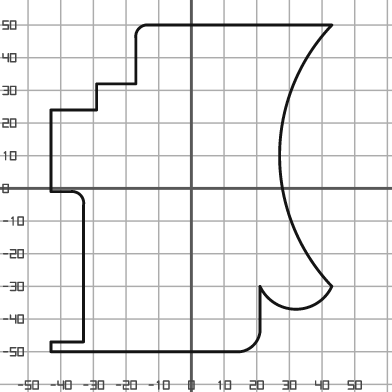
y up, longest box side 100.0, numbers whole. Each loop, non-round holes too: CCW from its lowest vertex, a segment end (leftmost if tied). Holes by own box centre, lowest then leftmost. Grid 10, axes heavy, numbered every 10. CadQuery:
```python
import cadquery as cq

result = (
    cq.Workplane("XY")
    .moveTo(-43.0, -50.0)
    .lineTo(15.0, -50.0)
    .threePointArc((19.0, -48.0), (21.0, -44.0))
    .lineTo(21.0, -30.0)
    .threePointArc((32.0, -37.0), (43.0, -30.0))
    .threePointArc((27.0, 10.0), (43.0, 50.0))
    .lineTo(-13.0, 50.0)
    .threePointArc((-16.0, 49.0), (-17.0, 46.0))
    .lineTo(-17.0, 32.0)
    .lineTo(-29.0, 32.0)
    .lineTo(-29.0, 24.0)
    .lineTo(-43.0, 24.0)
    .lineTo(-43.0, -1.0)
    .lineTo(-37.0, -1.0)
    .threePointArc((-34.0, -2.0), (-33.0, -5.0))
    .lineTo(-33.0, -47.0)
    .lineTo(-43.0, -47.0)
    .close()
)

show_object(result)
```